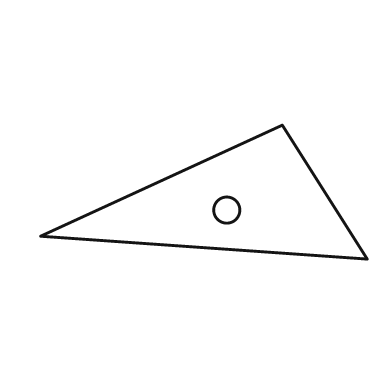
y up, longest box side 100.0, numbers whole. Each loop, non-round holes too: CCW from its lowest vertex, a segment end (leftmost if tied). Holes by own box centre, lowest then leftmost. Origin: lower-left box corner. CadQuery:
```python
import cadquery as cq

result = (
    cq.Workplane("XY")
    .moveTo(100.0, 0.0)
    .lineTo(74.0, 41.0)
    .lineTo(0.0, 7.0)
    .close()
    .moveTo(57.0, 15.0)
    .circle(4.0)
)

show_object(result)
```